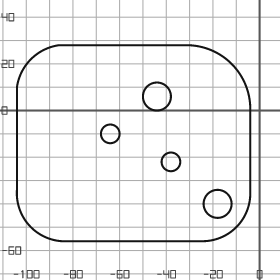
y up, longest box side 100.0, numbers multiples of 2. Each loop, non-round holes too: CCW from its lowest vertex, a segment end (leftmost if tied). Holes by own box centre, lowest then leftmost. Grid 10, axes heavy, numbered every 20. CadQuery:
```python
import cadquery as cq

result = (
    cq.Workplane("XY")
    .moveTo(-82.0, -56.0)
    .lineTo(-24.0, -56.0)
    .threePointArc((-10.0, -50.0), (-4.0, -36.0))
    .lineTo(-4.0, 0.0)
    .threePointArc((-12.0, 20.0), (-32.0, 28.0))
    .lineTo(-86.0, 28.0)
    .threePointArc((-98.0, 22.0), (-104.0, 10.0))
    .lineTo(-104.0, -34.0)
    .threePointArc((-98.0, -50.0), (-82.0, -56.0))
    .close()
    .moveTo(-18.0, -40.0)
    .circle(6.0)
    .moveTo(-38.0, -22.0)
    .circle(4.0)
    .moveTo(-64.0, -10.0)
    .circle(4.0)
    .moveTo(-44.0, 6.0)
    .circle(6.0)
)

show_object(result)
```